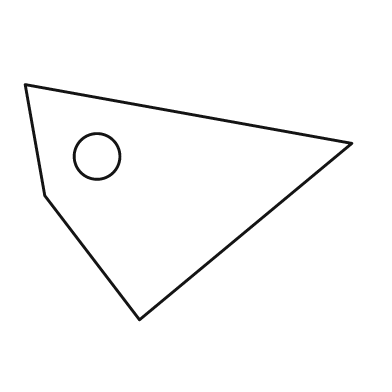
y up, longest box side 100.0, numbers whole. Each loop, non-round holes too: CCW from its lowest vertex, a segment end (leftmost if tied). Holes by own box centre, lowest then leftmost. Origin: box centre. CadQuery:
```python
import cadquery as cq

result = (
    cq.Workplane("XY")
    .moveTo(-15.0, -36.0)
    .lineTo(50.0, 18.0)
    .lineTo(-50.0, 36.0)
    .lineTo(-44.0, 2.0)
    .close()
    .moveTo(-28.0, 14.0)
    .circle(7.0)
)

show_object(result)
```